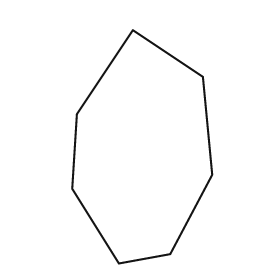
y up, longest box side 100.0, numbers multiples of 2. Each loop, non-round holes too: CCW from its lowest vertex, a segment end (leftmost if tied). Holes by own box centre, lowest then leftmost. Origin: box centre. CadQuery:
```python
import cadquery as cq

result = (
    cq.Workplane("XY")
    .moveTo(-10.0, -50.0)
    .lineTo(12.0, -46.0)
    .lineTo(30.0, -12.0)
    .lineTo(26.0, 30.0)
    .lineTo(-4.0, 50.0)
    .lineTo(-28.0, 14.0)
    .lineTo(-30.0, -18.0)
    .close()
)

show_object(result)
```